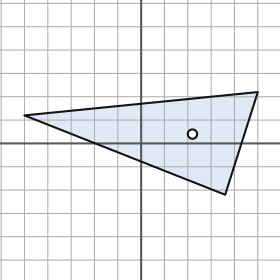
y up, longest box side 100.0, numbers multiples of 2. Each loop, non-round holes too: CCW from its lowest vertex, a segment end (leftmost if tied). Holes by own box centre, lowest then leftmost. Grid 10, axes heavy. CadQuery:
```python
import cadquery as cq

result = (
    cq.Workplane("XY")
    .moveTo(36.0, -22.0)
    .lineTo(50.0, 22.0)
    .lineTo(-50.0, 12.0)
    .close()
    .moveTo(22.0, 4.0)
    .circle(2.0)
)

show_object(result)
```